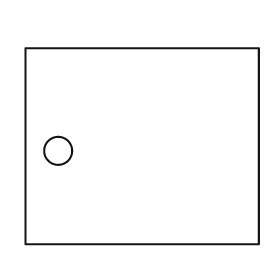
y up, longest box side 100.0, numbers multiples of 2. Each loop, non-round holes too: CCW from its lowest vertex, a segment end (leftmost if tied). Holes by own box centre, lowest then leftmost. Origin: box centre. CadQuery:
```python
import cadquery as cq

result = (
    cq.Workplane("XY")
    .moveTo(-50.0, -42.0)
    .lineTo(50.0, -42.0)
    .lineTo(50.0, 42.0)
    .lineTo(-50.0, 42.0)
    .close()
    .moveTo(-36.0, -2.0)
    .circle(6.0)
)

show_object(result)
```